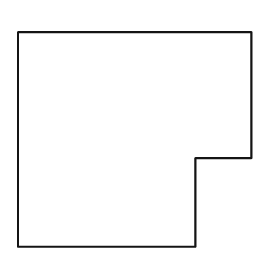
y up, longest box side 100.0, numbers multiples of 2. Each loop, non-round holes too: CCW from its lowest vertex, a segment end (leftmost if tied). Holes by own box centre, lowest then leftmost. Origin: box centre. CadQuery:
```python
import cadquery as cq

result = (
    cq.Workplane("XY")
    .moveTo(-50.0, -46.0)
    .lineTo(26.0, -46.0)
    .lineTo(26.0, -8.0)
    .lineTo(50.0, -8.0)
    .lineTo(50.0, 46.0)
    .lineTo(-50.0, 46.0)
    .close()
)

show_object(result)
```